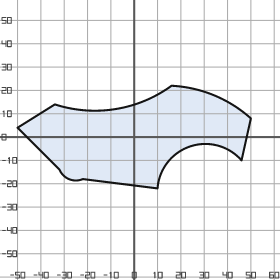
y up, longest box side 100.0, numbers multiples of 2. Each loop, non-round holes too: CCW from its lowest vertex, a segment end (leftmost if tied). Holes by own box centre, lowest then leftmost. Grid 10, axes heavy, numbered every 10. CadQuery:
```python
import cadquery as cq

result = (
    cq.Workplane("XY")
    .moveTo(10.0, -22.0)
    .threePointArc((24.0, -4.0), (46.0, -10.0))
    .lineTo(50.0, 8.0)
    .threePointArc((34.0, 18.0), (16.0, 22.0))
    .threePointArc((-8.0, 12.0), (-34.0, 14.0))
    .lineTo(-50.0, 4.0)
    .lineTo(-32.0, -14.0)
    .threePointArc((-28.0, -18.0), (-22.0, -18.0))
    .close()
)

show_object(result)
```